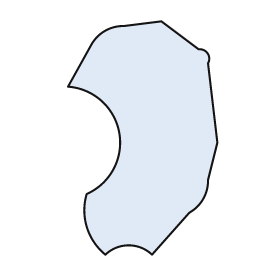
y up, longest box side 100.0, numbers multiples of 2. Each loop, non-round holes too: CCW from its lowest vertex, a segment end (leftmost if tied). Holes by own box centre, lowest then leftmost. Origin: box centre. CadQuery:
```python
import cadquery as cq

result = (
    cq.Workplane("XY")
    .moveTo(-16.0, -50.0)
    .threePointArc((-6.0, -46.0), (4.0, -50.0))
    .lineTo(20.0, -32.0)
    .threePointArc((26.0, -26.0), (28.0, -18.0))
    .lineTo(32.0, -2.0)
    .lineTo(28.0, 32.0)
    .threePointArc((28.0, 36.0), (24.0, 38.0))
    .lineTo(8.0, 50.0)
    .lineTo(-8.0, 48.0)
    .threePointArc((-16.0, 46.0), (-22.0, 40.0))
    .lineTo(-32.0, 22.0)
    .threePointArc((-10.0, 2.0), (-24.0, -24.0))
    .threePointArc((-24.0, -38.0), (-16.0, -50.0))
    .close()
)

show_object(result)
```